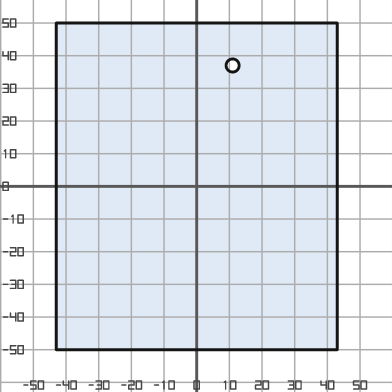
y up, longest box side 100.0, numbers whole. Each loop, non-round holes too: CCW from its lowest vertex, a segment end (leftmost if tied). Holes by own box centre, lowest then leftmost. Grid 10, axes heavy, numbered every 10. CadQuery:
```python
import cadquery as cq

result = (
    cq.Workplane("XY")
    .moveTo(-43.0, -50.0)
    .lineTo(43.0, -50.0)
    .lineTo(43.0, 50.0)
    .lineTo(-43.0, 50.0)
    .close()
    .moveTo(11.0, 37.0)
    .circle(2.0)
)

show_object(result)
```